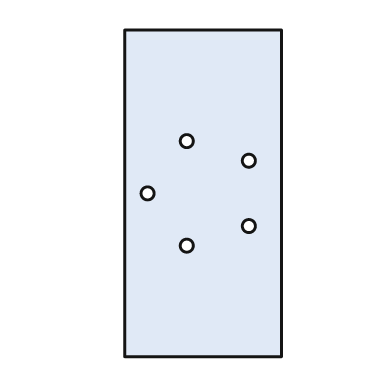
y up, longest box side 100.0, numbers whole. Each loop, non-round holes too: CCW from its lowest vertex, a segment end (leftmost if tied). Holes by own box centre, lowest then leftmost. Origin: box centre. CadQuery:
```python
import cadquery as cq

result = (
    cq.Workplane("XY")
    .moveTo(-24.0, -50.0)
    .lineTo(24.0, -50.0)
    .lineTo(24.0, 50.0)
    .lineTo(-24.0, 50.0)
    .close()
    .moveTo(-5.0, -16.0)
    .circle(2.0)
    .moveTo(14.0, -10.0)
    .circle(2.0)
    .moveTo(-17.0, 0.0)
    .circle(2.0)
    .moveTo(14.0, 10.0)
    .circle(2.0)
    .moveTo(-5.0, 16.0)
    .circle(2.0)
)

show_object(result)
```